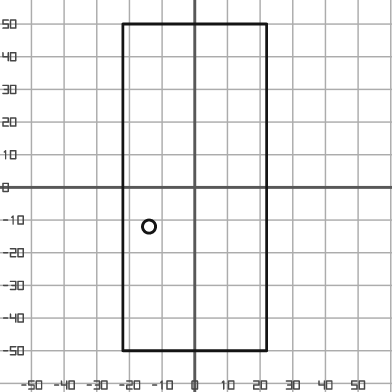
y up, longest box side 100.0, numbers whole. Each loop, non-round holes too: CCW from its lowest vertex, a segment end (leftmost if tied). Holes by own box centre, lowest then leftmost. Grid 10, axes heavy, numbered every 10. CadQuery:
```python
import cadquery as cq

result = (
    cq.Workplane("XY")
    .moveTo(-22.0, -50.0)
    .lineTo(22.0, -50.0)
    .lineTo(22.0, 50.0)
    .lineTo(-22.0, 50.0)
    .close()
    .moveTo(-14.0, -12.0)
    .circle(2.0)
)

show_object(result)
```